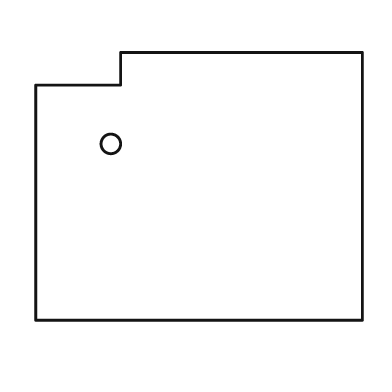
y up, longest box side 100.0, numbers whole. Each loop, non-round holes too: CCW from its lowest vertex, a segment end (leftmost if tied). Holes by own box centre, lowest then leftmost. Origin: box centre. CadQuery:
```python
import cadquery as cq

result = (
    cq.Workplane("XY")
    .moveTo(-50.0, -41.0)
    .lineTo(50.0, -41.0)
    .lineTo(50.0, 41.0)
    .lineTo(-24.0, 41.0)
    .lineTo(-24.0, 31.0)
    .lineTo(-50.0, 31.0)
    .close()
    .moveTo(-27.0, 13.0)
    .circle(3.0)
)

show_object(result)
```